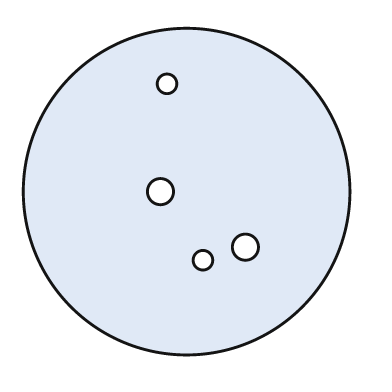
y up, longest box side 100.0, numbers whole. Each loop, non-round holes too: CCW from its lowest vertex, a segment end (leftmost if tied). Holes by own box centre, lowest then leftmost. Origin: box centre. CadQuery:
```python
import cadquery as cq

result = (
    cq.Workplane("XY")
    .moveTo(0.0, 0.0)
    .circle(50.0)
    .moveTo(5.0, -21.0)
    .circle(3.0)
    .moveTo(18.0, -17.0)
    .circle(4.0)
    .moveTo(-8.0, 0.0)
    .circle(4.0)
    .moveTo(-6.0, 33.0)
    .circle(3.0)
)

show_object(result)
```